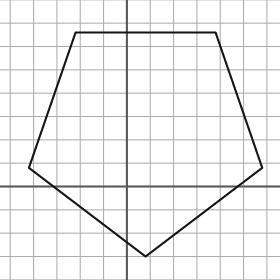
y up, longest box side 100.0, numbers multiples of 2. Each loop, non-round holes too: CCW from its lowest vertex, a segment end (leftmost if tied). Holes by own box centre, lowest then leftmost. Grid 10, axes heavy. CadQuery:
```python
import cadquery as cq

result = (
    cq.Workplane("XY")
    .moveTo(8.0, -30.0)
    .lineTo(58.0, 8.0)
    .lineTo(38.0, 66.0)
    .lineTo(-22.0, 66.0)
    .lineTo(-42.0, 8.0)
    .close()
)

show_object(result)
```